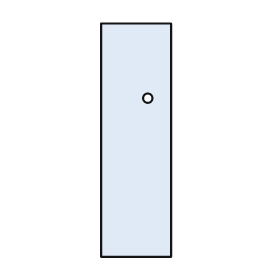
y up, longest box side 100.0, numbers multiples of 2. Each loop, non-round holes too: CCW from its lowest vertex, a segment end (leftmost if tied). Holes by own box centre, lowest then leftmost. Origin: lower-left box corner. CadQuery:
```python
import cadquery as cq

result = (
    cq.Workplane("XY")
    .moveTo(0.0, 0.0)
    .lineTo(30.0, 0.0)
    .lineTo(30.0, 100.0)
    .lineTo(0.0, 100.0)
    .close()
    .moveTo(20.0, 68.0)
    .circle(2.0)
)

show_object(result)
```